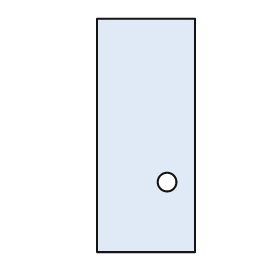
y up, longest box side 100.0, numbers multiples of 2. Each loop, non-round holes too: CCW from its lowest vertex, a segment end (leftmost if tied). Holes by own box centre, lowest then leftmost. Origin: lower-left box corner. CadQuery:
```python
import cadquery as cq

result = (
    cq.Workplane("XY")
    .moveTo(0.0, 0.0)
    .lineTo(42.0, 0.0)
    .lineTo(42.0, 100.0)
    .lineTo(0.0, 100.0)
    .close()
    .moveTo(30.0, 30.0)
    .circle(4.0)
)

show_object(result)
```